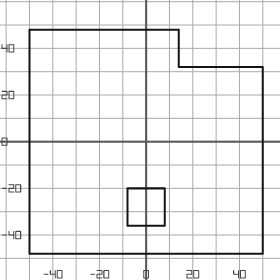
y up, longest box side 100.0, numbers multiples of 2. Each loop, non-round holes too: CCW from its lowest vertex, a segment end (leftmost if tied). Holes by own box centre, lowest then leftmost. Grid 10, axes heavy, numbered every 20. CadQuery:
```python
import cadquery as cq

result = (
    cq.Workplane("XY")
    .moveTo(-50.0, -48.0)
    .lineTo(50.0, -48.0)
    .lineTo(50.0, 32.0)
    .lineTo(14.0, 32.0)
    .lineTo(14.0, 48.0)
    .lineTo(-50.0, 48.0)
    .close()
    .moveTo(-8.0, -36.0)
    .lineTo(8.0, -36.0)
    .lineTo(8.0, -20.0)
    .lineTo(-8.0, -20.0)
    .close()
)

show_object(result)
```